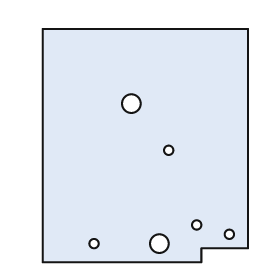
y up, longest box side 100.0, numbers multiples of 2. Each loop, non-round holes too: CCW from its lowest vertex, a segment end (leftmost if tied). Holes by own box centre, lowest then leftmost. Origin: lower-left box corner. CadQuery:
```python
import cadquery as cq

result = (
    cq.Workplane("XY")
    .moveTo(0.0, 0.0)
    .lineTo(68.0, 0.0)
    .lineTo(68.0, 6.0)
    .lineTo(88.0, 6.0)
    .lineTo(88.0, 100.0)
    .lineTo(0.0, 100.0)
    .close()
    .moveTo(22.0, 8.0)
    .circle(2.0)
    .moveTo(50.0, 8.0)
    .circle(4.0)
    .moveTo(80.0, 12.0)
    .circle(2.0)
    .moveTo(66.0, 16.0)
    .circle(2.0)
    .moveTo(54.0, 48.0)
    .circle(2.0)
    .moveTo(38.0, 68.0)
    .circle(4.0)
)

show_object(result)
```